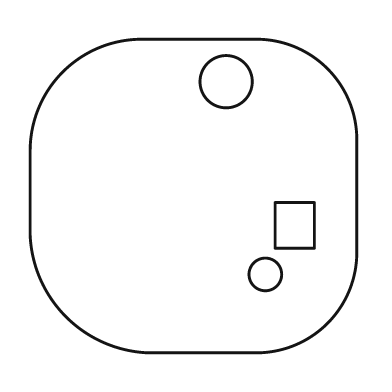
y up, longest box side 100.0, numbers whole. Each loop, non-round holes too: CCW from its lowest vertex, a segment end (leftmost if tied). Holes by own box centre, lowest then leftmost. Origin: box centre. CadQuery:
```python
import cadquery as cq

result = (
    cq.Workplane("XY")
    .moveTo(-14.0, -48.0)
    .lineTo(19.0, -48.0)
    .threePointArc((41.0, -39.0), (50.0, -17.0))
    .lineTo(50.0, 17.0)
    .threePointArc((41.0, 39.0), (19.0, 48.0))
    .lineTo(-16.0, 48.0)
    .threePointArc((-40.0, 38.0), (-50.0, 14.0))
    .lineTo(-50.0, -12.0)
    .threePointArc((-39.0, -37.0), (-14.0, -48.0))
    .close()
    .moveTo(22.0, -24.0)
    .circle(5.0)
    .moveTo(25.0, -16.0)
    .lineTo(37.0, -16.0)
    .lineTo(37.0, -2.0)
    .lineTo(25.0, -2.0)
    .close()
    .moveTo(10.0, 35.0)
    .circle(8.0)
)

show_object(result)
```